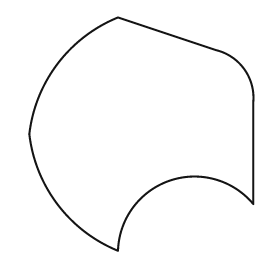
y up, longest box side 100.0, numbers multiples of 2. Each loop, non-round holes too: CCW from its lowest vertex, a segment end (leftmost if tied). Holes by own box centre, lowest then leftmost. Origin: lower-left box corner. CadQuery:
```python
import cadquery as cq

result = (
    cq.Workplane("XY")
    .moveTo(38.0, 0.0)
    .threePointArc((60.0, 30.0), (96.0, 20.0))
    .lineTo(96.0, 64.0)
    .threePointArc((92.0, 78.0), (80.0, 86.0))
    .lineTo(38.0, 100.0)
    .threePointArc((12.0, 80.0), (0.0, 50.0))
    .threePointArc((12.0, 20.0), (38.0, 0.0))
    .close()
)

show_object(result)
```